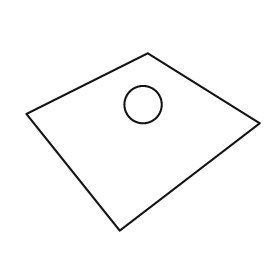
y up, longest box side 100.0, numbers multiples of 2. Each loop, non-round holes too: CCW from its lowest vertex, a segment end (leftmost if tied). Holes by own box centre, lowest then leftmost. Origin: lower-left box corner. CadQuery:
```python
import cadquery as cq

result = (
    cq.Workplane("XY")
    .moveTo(40.0, 0.0)
    .lineTo(100.0, 46.0)
    .lineTo(52.0, 76.0)
    .lineTo(0.0, 50.0)
    .close()
    .moveTo(50.0, 54.0)
    .circle(8.0)
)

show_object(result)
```